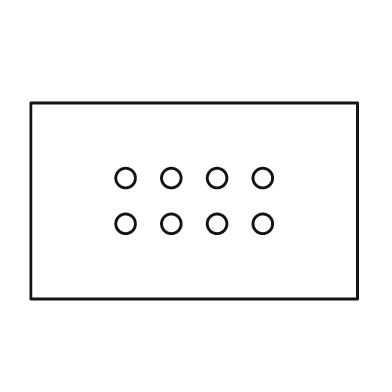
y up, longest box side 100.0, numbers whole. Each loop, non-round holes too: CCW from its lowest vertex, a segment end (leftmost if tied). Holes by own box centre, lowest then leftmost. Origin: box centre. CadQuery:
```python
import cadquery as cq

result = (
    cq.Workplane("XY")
    .moveTo(-50.0, -30.0)
    .lineTo(50.0, -30.0)
    .lineTo(50.0, 30.0)
    .lineTo(-50.0, 30.0)
    .close()
    .moveTo(-21.0, -7.0)
    .circle(3.0)
    .moveTo(-7.0, -7.0)
    .circle(3.0)
    .moveTo(7.0, -7.0)
    .circle(3.0)
    .moveTo(21.0, -7.0)
    .circle(3.0)
    .moveTo(-21.0, 7.0)
    .circle(3.0)
    .moveTo(-7.0, 7.0)
    .circle(3.0)
    .moveTo(7.0, 7.0)
    .circle(3.0)
    .moveTo(21.0, 7.0)
    .circle(3.0)
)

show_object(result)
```